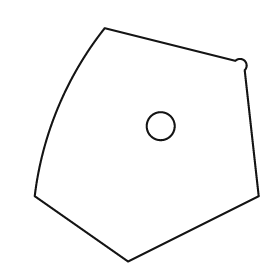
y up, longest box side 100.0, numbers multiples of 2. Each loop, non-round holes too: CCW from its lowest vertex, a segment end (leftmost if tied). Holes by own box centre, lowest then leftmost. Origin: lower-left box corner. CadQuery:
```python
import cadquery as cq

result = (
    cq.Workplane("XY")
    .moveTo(40.0, 0.0)
    .lineTo(96.0, 28.0)
    .lineTo(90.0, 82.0)
    .threePointArc((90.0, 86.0), (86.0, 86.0))
    .lineTo(30.0, 100.0)
    .threePointArc((10.0, 66.0), (0.0, 28.0))
    .close()
    .moveTo(54.0, 58.0)
    .circle(6.0)
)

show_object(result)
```